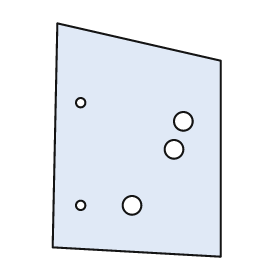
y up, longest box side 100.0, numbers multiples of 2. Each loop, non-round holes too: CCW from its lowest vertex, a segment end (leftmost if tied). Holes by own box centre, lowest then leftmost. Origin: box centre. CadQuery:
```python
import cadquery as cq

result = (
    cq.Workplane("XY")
    .moveTo(36.0, -50.0)
    .lineTo(36.0, 34.0)
    .lineTo(-34.0, 50.0)
    .lineTo(-36.0, -46.0)
    .close()
    .moveTo(-24.0, -28.0)
    .circle(2.0)
    .moveTo(-2.0, -28.0)
    .circle(4.0)
    .moveTo(16.0, -4.0)
    .circle(4.0)
    .moveTo(20.0, 8.0)
    .circle(4.0)
    .moveTo(-24.0, 16.0)
    .circle(2.0)
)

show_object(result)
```